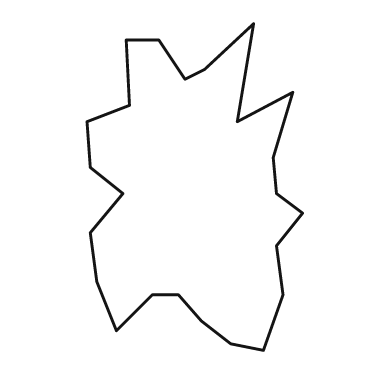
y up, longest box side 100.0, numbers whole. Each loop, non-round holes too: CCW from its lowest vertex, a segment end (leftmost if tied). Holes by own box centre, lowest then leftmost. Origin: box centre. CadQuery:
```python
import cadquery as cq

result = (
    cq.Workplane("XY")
    .moveTo(21.0, -50.0)
    .lineTo(27.0, -33.0)
    .lineTo(25.0, -18.0)
    .lineTo(33.0, -8.0)
    .lineTo(25.0, -2.0)
    .lineTo(24.0, 9.0)
    .lineTo(30.0, 29.0)
    .lineTo(13.0, 20.0)
    .lineTo(18.0, 50.0)
    .lineTo(3.0, 36.0)
    .lineTo(-3.0, 33.0)
    .lineTo(-11.0, 45.0)
    .lineTo(-21.0, 45.0)
    .lineTo(-20.0, 25.0)
    .lineTo(-33.0, 20.0)
    .lineTo(-32.0, 6.0)
    .lineTo(-22.0, -2.0)
    .lineTo(-32.0, -14.0)
    .lineTo(-30.0, -29.0)
    .lineTo(-24.0, -44.0)
    .lineTo(-13.0, -33.0)
    .lineTo(-5.0, -33.0)
    .lineTo(2.0, -41.0)
    .lineTo(11.0, -48.0)
    .close()
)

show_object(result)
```